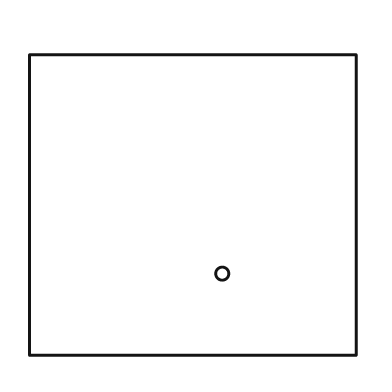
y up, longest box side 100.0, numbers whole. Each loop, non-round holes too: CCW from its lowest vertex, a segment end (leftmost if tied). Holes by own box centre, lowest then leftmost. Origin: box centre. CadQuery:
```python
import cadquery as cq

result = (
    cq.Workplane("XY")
    .moveTo(-50.0, -46.0)
    .lineTo(50.0, -46.0)
    .lineTo(50.0, 46.0)
    .lineTo(-50.0, 46.0)
    .close()
    .moveTo(9.0, -21.0)
    .circle(2.0)
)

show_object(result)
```